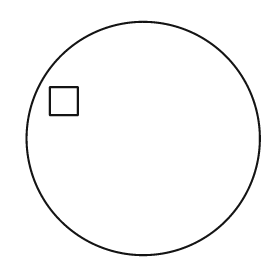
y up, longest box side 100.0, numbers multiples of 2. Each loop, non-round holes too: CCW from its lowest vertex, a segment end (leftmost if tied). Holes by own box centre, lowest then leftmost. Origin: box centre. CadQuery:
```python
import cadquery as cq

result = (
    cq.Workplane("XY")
    .moveTo(0.0, 0.0)
    .circle(50.0)
    .moveTo(-40.0, 10.0)
    .lineTo(-28.0, 10.0)
    .lineTo(-28.0, 22.0)
    .lineTo(-40.0, 22.0)
    .close()
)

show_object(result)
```